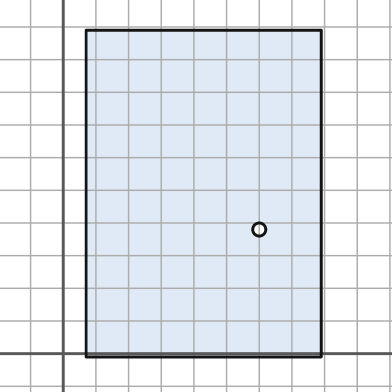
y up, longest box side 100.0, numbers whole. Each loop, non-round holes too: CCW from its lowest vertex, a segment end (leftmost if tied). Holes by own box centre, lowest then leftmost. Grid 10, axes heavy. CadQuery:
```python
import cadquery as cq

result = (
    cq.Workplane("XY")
    .moveTo(7.0, -1.0)
    .lineTo(79.0, -1.0)
    .lineTo(79.0, 99.0)
    .lineTo(7.0, 99.0)
    .close()
    .moveTo(60.0, 38.0)
    .circle(2.0)
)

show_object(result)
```